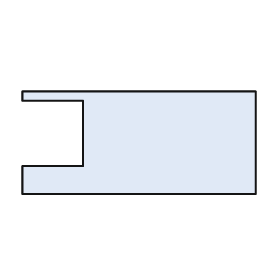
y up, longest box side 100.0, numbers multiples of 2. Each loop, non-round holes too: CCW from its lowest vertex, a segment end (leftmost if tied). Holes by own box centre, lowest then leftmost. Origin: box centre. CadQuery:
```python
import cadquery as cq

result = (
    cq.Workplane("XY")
    .moveTo(-50.0, -22.0)
    .lineTo(50.0, -22.0)
    .lineTo(50.0, 22.0)
    .lineTo(-50.0, 22.0)
    .lineTo(-50.0, 18.0)
    .lineTo(-24.0, 18.0)
    .lineTo(-24.0, -10.0)
    .lineTo(-50.0, -10.0)
    .close()
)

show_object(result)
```